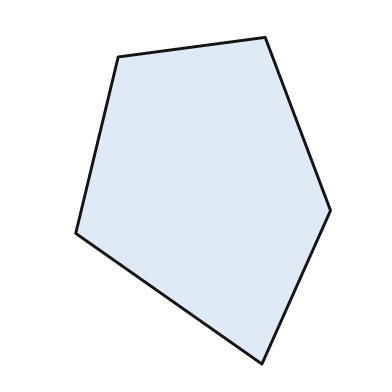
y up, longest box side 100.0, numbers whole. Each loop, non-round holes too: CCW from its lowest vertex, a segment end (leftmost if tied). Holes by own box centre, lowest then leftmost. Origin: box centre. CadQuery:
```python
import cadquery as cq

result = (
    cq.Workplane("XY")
    .moveTo(18.0, -50.0)
    .lineTo(39.0, -3.0)
    .lineTo(19.0, 50.0)
    .lineTo(-26.0, 44.0)
    .lineTo(-39.0, -10.0)
    .close()
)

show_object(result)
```